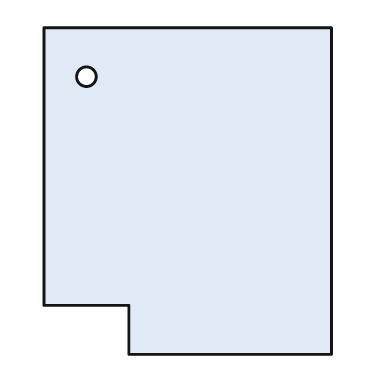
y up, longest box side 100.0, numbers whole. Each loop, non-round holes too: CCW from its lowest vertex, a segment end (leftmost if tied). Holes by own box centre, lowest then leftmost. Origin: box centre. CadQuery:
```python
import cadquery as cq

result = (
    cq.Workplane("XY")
    .moveTo(-18.0, -50.0)
    .lineTo(44.0, -50.0)
    .lineTo(44.0, 50.0)
    .lineTo(-44.0, 50.0)
    .lineTo(-44.0, -35.0)
    .lineTo(-18.0, -35.0)
    .close()
    .moveTo(-31.0, 35.0)
    .circle(3.0)
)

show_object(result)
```